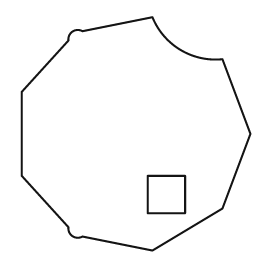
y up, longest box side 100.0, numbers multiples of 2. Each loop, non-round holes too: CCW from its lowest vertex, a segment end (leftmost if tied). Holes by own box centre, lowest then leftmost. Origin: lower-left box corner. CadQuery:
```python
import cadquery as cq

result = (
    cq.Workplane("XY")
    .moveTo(56.0, 0.0)
    .lineTo(86.0, 18.0)
    .lineTo(98.0, 50.0)
    .lineTo(86.0, 82.0)
    .threePointArc((68.0, 86.0), (56.0, 100.0))
    .lineTo(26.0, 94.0)
    .threePointArc((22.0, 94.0), (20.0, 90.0))
    .lineTo(0.0, 68.0)
    .lineTo(0.0, 32.0)
    .lineTo(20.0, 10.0)
    .threePointArc((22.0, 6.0), (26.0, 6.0))
    .close()
    .moveTo(54.0, 16.0)
    .lineTo(70.0, 16.0)
    .lineTo(70.0, 32.0)
    .lineTo(54.0, 32.0)
    .close()
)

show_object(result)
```